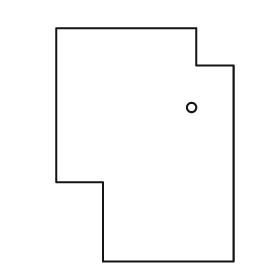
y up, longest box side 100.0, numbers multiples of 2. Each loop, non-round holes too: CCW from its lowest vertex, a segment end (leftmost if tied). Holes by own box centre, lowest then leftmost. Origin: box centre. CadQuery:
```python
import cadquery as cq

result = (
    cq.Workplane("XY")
    .moveTo(-18.0, -50.0)
    .lineTo(38.0, -50.0)
    .lineTo(38.0, 34.0)
    .lineTo(22.0, 34.0)
    .lineTo(22.0, 50.0)
    .lineTo(-38.0, 50.0)
    .lineTo(-38.0, -16.0)
    .lineTo(-18.0, -16.0)
    .close()
    .moveTo(20.0, 16.0)
    .circle(2.0)
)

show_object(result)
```